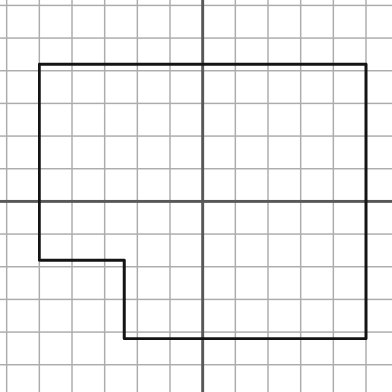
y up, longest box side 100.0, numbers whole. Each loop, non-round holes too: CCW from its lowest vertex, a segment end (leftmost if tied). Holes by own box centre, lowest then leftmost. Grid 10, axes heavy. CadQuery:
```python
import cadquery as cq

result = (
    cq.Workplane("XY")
    .moveTo(-24.0, -42.0)
    .lineTo(50.0, -42.0)
    .lineTo(50.0, 42.0)
    .lineTo(-50.0, 42.0)
    .lineTo(-50.0, -18.0)
    .lineTo(-24.0, -18.0)
    .close()
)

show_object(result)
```